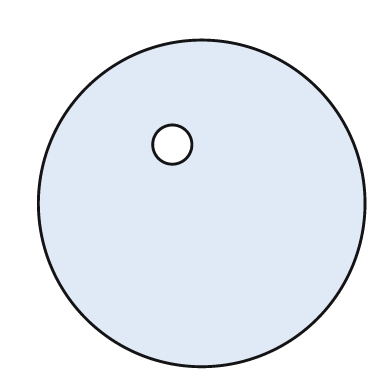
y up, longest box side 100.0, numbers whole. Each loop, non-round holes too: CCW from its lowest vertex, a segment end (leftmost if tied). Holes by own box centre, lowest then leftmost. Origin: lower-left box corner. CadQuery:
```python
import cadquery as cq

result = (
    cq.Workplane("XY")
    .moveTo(50.0, 50.0)
    .circle(50.0)
    .moveTo(41.0, 68.0)
    .circle(6.0)
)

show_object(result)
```